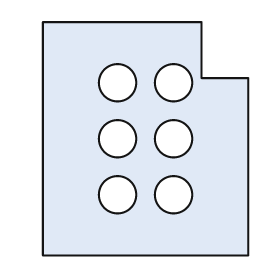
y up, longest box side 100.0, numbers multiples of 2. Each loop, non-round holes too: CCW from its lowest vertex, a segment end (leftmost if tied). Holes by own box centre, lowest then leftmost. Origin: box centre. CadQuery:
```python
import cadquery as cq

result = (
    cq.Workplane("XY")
    .moveTo(-44.0, -50.0)
    .lineTo(44.0, -50.0)
    .lineTo(44.0, 26.0)
    .lineTo(24.0, 26.0)
    .lineTo(24.0, 50.0)
    .lineTo(-44.0, 50.0)
    .close()
    .moveTo(-12.0, -24.0)
    .circle(8.0)
    .moveTo(12.0, -24.0)
    .circle(8.0)
    .moveTo(-12.0, 0.0)
    .circle(8.0)
    .moveTo(12.0, 0.0)
    .circle(8.0)
    .moveTo(-12.0, 24.0)
    .circle(8.0)
    .moveTo(12.0, 24.0)
    .circle(8.0)
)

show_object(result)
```